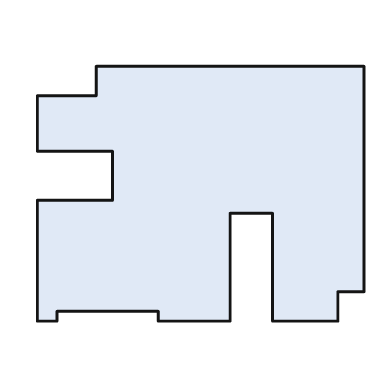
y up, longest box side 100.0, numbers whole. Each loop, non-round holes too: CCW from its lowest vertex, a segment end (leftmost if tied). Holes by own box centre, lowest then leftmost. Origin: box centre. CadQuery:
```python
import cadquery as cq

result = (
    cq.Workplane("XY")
    .moveTo(-50.0, -39.0)
    .lineTo(-44.0, -39.0)
    .lineTo(-44.0, -36.0)
    .lineTo(-13.0, -36.0)
    .lineTo(-13.0, -39.0)
    .lineTo(9.0, -39.0)
    .lineTo(9.0, -6.0)
    .lineTo(22.0, -6.0)
    .lineTo(22.0, -39.0)
    .lineTo(42.0, -39.0)
    .lineTo(42.0, -30.0)
    .lineTo(50.0, -30.0)
    .lineTo(50.0, 39.0)
    .lineTo(-32.0, 39.0)
    .lineTo(-32.0, 30.0)
    .lineTo(-50.0, 30.0)
    .lineTo(-50.0, 13.0)
    .lineTo(-27.0, 13.0)
    .lineTo(-27.0, -2.0)
    .lineTo(-50.0, -2.0)
    .close()
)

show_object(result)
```